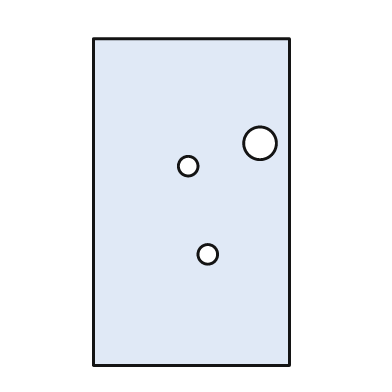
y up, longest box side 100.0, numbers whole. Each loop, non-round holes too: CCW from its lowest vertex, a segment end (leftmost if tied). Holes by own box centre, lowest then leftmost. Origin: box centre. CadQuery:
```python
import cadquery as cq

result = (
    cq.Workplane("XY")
    .moveTo(-30.0, -50.0)
    .lineTo(30.0, -50.0)
    .lineTo(30.0, 50.0)
    .lineTo(-30.0, 50.0)
    .close()
    .moveTo(5.0, -16.0)
    .circle(3.0)
    .moveTo(-1.0, 11.0)
    .circle(3.0)
    .moveTo(21.0, 18.0)
    .circle(5.0)
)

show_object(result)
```